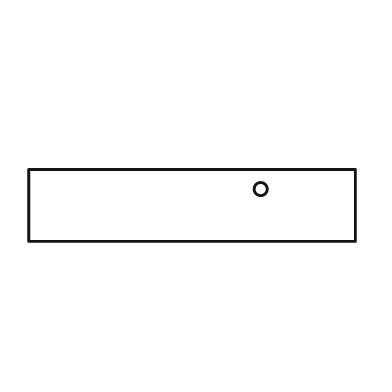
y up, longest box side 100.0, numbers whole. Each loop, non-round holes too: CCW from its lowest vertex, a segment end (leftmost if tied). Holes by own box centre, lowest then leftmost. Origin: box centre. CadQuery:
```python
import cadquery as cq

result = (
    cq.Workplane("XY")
    .moveTo(-50.0, -11.0)
    .lineTo(50.0, -11.0)
    .lineTo(50.0, 11.0)
    .lineTo(-50.0, 11.0)
    .close()
    .moveTo(21.0, 5.0)
    .circle(2.0)
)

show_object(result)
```